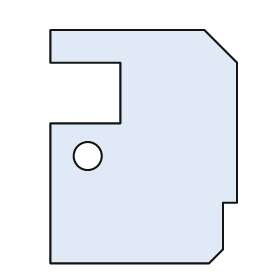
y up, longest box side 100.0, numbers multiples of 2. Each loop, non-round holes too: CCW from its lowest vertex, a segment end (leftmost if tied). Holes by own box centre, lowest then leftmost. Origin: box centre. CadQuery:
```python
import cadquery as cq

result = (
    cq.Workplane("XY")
    .moveTo(-40.0, -50.0)
    .lineTo(28.0, -50.0)
    .lineTo(34.0, -44.0)
    .lineTo(34.0, -24.0)
    .lineTo(40.0, -24.0)
    .lineTo(40.0, 36.0)
    .lineTo(26.0, 50.0)
    .lineTo(-40.0, 50.0)
    .lineTo(-40.0, 36.0)
    .lineTo(-10.0, 36.0)
    .lineTo(-10.0, 10.0)
    .lineTo(-40.0, 10.0)
    .close()
    .moveTo(-24.0, -4.0)
    .circle(6.0)
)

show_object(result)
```